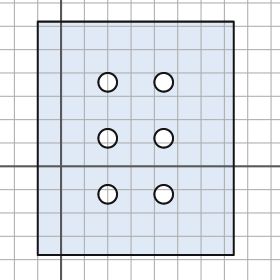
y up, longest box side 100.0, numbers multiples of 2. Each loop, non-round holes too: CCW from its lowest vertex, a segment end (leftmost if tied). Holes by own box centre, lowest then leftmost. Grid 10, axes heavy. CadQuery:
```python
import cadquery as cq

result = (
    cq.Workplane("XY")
    .moveTo(-10.0, -38.0)
    .lineTo(74.0, -38.0)
    .lineTo(74.0, 62.0)
    .lineTo(-10.0, 62.0)
    .close()
    .moveTo(20.0, -12.0)
    .circle(4.0)
    .moveTo(44.0, -12.0)
    .circle(4.0)
    .moveTo(20.0, 12.0)
    .circle(4.0)
    .moveTo(44.0, 12.0)
    .circle(4.0)
    .moveTo(20.0, 36.0)
    .circle(4.0)
    .moveTo(44.0, 36.0)
    .circle(4.0)
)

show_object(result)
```